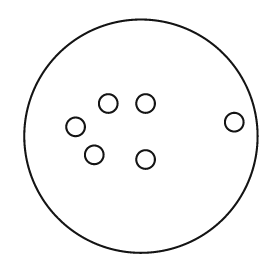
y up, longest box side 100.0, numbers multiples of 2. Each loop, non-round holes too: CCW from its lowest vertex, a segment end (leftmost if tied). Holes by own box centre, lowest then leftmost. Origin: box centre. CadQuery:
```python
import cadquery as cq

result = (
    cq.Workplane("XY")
    .moveTo(0.0, 0.0)
    .circle(50.0)
    .moveTo(2.0, -10.0)
    .circle(4.0)
    .moveTo(-20.0, -8.0)
    .circle(4.0)
    .moveTo(-28.0, 4.0)
    .circle(4.0)
    .moveTo(40.0, 6.0)
    .circle(4.0)
    .moveTo(-14.0, 14.0)
    .circle(4.0)
    .moveTo(2.0, 14.0)
    .circle(4.0)
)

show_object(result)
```